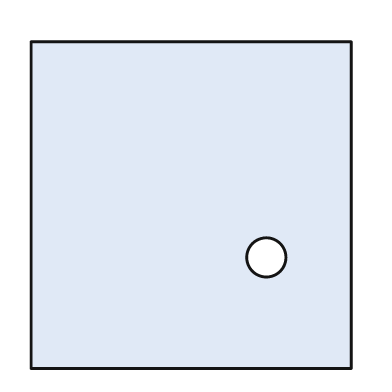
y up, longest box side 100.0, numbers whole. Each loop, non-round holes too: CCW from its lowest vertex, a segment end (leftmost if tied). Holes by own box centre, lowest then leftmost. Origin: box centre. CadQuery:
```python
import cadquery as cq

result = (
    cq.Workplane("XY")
    .moveTo(-49.0, -50.0)
    .lineTo(49.0, -50.0)
    .lineTo(49.0, 50.0)
    .lineTo(-49.0, 50.0)
    .close()
    .moveTo(23.0, -16.0)
    .circle(6.0)
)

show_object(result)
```